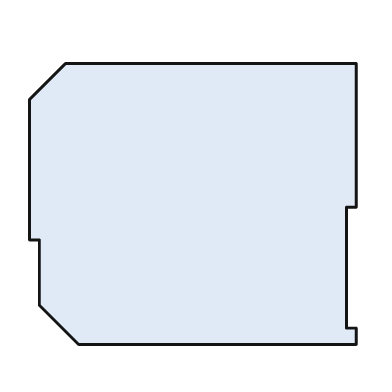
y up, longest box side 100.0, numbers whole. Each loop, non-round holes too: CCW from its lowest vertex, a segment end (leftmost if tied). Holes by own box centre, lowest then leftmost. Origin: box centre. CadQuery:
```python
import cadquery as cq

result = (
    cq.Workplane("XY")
    .moveTo(-35.0, -43.0)
    .lineTo(50.0, -43.0)
    .lineTo(50.0, -38.0)
    .lineTo(47.0, -38.0)
    .lineTo(47.0, -1.0)
    .lineTo(50.0, -1.0)
    .lineTo(50.0, 43.0)
    .lineTo(-39.0, 43.0)
    .lineTo(-50.0, 32.0)
    .lineTo(-50.0, -11.0)
    .lineTo(-47.0, -11.0)
    .lineTo(-47.0, -31.0)
    .close()
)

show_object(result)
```